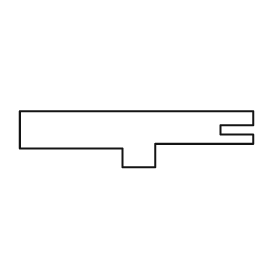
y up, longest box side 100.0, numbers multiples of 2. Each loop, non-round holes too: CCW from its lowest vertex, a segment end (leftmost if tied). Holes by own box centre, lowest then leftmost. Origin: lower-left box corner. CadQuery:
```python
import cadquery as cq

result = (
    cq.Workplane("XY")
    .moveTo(44.0, 0.0)
    .lineTo(58.0, 0.0)
    .lineTo(58.0, 10.0)
    .lineTo(100.0, 10.0)
    .lineTo(100.0, 14.0)
    .lineTo(86.0, 14.0)
    .lineTo(86.0, 18.0)
    .lineTo(100.0, 18.0)
    .lineTo(100.0, 24.0)
    .lineTo(0.0, 24.0)
    .lineTo(0.0, 8.0)
    .lineTo(44.0, 8.0)
    .close()
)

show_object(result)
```